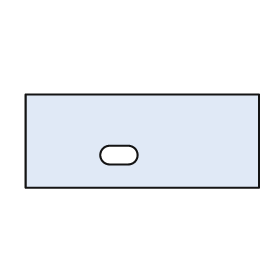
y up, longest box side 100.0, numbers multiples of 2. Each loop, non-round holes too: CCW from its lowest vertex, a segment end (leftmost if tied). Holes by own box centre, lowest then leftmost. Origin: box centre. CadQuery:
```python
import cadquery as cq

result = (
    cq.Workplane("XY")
    .moveTo(-50.0, -20.0)
    .lineTo(50.0, -20.0)
    .lineTo(50.0, 20.0)
    .lineTo(-50.0, 20.0)
    .close()
    .moveTo(-14.0, -10.0)
    .lineTo(-6.0, -10.0)
    .threePointArc((-2.0, -6.0), (-6.0, -2.0))
    .lineTo(-14.0, -2.0)
    .threePointArc((-18.0, -6.0), (-14.0, -10.0))
    .close()
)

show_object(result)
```